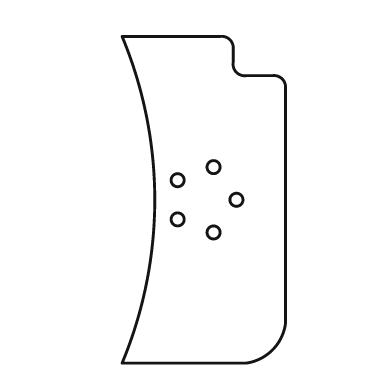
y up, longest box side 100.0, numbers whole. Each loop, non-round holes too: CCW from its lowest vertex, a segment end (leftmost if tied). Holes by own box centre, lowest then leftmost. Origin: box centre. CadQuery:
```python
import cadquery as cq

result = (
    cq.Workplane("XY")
    .moveTo(-25.0, -50.0)
    .lineTo(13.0, -50.0)
    .threePointArc((21.0, -46.0), (25.0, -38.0))
    .lineTo(25.0, 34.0)
    .threePointArc((24.0, 37.0), (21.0, 38.0))
    .lineTo(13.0, 38.0)
    .threePointArc((10.0, 39.0), (9.0, 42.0))
    .lineTo(9.0, 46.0)
    .threePointArc((8.0, 49.0), (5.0, 50.0))
    .lineTo(-25.0, 50.0)
    .threePointArc((-15.0, 0.0), (-25.0, -50.0))
    .close()
    .moveTo(3.0, -10.0)
    .circle(2.0)
    .moveTo(-8.0, -6.0)
    .circle(2.0)
    .moveTo(10.0, 0.0)
    .circle(2.0)
    .moveTo(-8.0, 6.0)
    .circle(2.0)
    .moveTo(3.0, 10.0)
    .circle(2.0)
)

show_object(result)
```